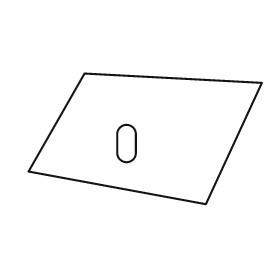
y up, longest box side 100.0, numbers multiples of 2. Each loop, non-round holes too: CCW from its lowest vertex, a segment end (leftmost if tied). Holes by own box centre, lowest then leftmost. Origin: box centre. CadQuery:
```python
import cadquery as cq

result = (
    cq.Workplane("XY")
    .moveTo(26.0, -28.0)
    .lineTo(50.0, 24.0)
    .lineTo(-26.0, 28.0)
    .lineTo(-50.0, -14.0)
    .close()
    .moveTo(-12.0, -6.0)
    .threePointArc((-8.0, -10.0), (-4.0, -6.0))
    .lineTo(-4.0, 2.0)
    .threePointArc((-8.0, 6.0), (-12.0, 2.0))
    .close()
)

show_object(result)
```